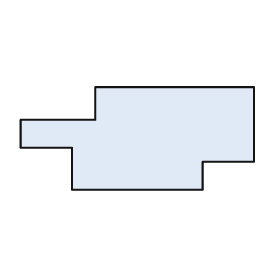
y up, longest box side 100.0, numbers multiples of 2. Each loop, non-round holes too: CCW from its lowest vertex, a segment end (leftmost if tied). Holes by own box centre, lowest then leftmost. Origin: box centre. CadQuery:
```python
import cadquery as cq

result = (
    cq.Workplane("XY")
    .moveTo(-28.0, -22.0)
    .lineTo(28.0, -22.0)
    .lineTo(28.0, -10.0)
    .lineTo(50.0, -10.0)
    .lineTo(50.0, 22.0)
    .lineTo(-18.0, 22.0)
    .lineTo(-18.0, 8.0)
    .lineTo(-50.0, 8.0)
    .lineTo(-50.0, -4.0)
    .lineTo(-28.0, -4.0)
    .close()
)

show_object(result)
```